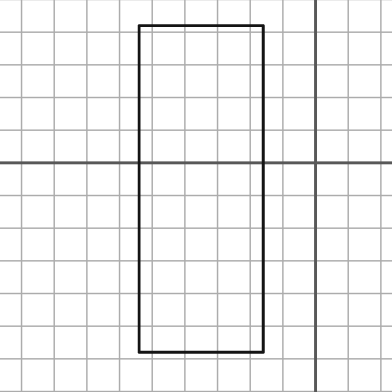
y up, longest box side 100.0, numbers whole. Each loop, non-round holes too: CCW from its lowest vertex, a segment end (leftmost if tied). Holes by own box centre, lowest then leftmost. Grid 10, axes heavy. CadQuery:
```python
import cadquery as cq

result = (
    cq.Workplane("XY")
    .moveTo(-54.0, -58.0)
    .lineTo(-16.0, -58.0)
    .lineTo(-16.0, 42.0)
    .lineTo(-54.0, 42.0)
    .close()
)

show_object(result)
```